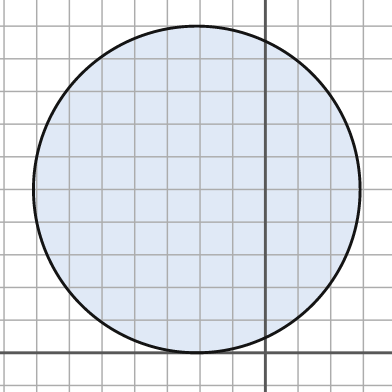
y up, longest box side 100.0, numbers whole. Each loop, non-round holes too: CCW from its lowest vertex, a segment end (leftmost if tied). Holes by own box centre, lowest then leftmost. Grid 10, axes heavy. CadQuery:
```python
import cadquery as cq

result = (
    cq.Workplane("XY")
    .moveTo(-21.0, 50.0)
    .circle(50.0)
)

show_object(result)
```